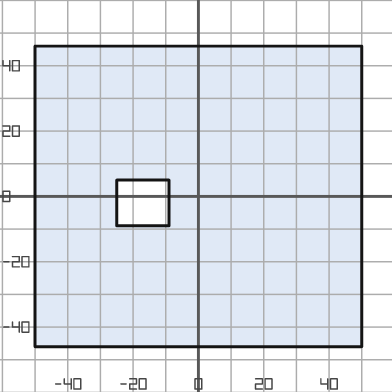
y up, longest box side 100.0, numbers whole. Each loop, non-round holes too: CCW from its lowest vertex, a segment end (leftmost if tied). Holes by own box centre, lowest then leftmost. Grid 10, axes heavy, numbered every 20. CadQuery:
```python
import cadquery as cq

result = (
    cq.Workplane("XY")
    .moveTo(-50.0, -46.0)
    .lineTo(50.0, -46.0)
    .lineTo(50.0, 46.0)
    .lineTo(-50.0, 46.0)
    .close()
    .moveTo(-25.0, -9.0)
    .lineTo(-9.0, -9.0)
    .lineTo(-9.0, 5.0)
    .lineTo(-25.0, 5.0)
    .close()
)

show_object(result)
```